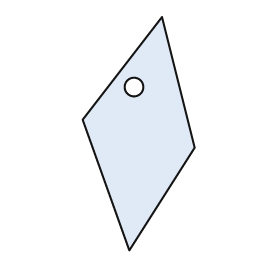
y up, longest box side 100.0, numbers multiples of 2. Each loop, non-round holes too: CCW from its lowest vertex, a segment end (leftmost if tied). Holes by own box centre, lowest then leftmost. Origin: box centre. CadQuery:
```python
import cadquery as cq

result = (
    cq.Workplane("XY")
    .moveTo(-4.0, -50.0)
    .lineTo(24.0, -6.0)
    .lineTo(10.0, 50.0)
    .lineTo(-24.0, 6.0)
    .close()
    .moveTo(-2.0, 20.0)
    .circle(4.0)
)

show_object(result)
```